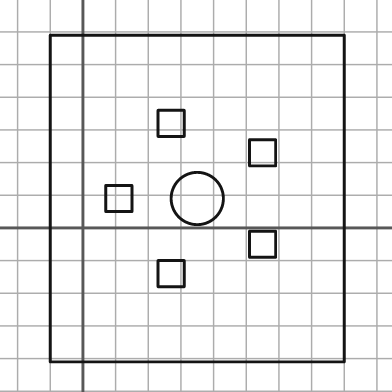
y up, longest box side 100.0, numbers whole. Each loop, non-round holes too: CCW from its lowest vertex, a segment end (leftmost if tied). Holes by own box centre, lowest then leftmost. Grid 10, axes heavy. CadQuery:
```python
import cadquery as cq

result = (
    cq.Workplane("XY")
    .moveTo(-10.0, -41.0)
    .lineTo(80.0, -41.0)
    .lineTo(80.0, 59.0)
    .lineTo(-10.0, 59.0)
    .close()
    .moveTo(23.0, -18.0)
    .lineTo(31.0, -18.0)
    .lineTo(31.0, -10.0)
    .lineTo(23.0, -10.0)
    .close()
    .moveTo(51.0, -9.0)
    .lineTo(59.0, -9.0)
    .lineTo(59.0, -1.0)
    .lineTo(51.0, -1.0)
    .close()
    .moveTo(7.0, 5.0)
    .lineTo(15.0, 5.0)
    .lineTo(15.0, 13.0)
    .lineTo(7.0, 13.0)
    .close()
    .moveTo(35.0, 9.0)
    .circle(8.0)
    .moveTo(51.0, 19.0)
    .lineTo(59.0, 19.0)
    .lineTo(59.0, 27.0)
    .lineTo(51.0, 27.0)
    .close()
    .moveTo(23.0, 28.0)
    .lineTo(31.0, 28.0)
    .lineTo(31.0, 36.0)
    .lineTo(23.0, 36.0)
    .close()
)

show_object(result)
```